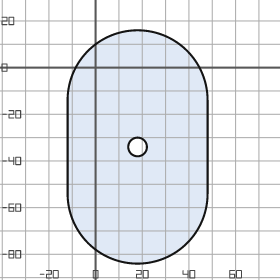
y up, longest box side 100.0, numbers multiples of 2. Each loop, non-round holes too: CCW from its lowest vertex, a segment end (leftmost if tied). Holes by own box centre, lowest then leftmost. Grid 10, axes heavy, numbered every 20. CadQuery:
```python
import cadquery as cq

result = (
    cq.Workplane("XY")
    .moveTo(-12.0, -54.0)
    .threePointArc((18.0, -84.0), (48.0, -54.0))
    .lineTo(48.0, -14.0)
    .threePointArc((18.0, 16.0), (-12.0, -14.0))
    .close()
    .moveTo(18.0, -34.0)
    .circle(4.0)
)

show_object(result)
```